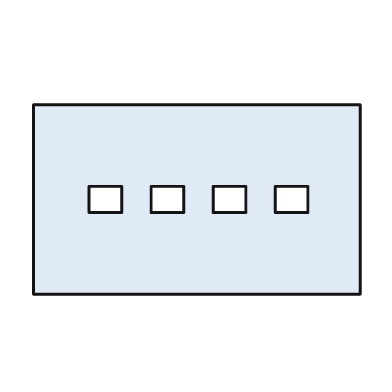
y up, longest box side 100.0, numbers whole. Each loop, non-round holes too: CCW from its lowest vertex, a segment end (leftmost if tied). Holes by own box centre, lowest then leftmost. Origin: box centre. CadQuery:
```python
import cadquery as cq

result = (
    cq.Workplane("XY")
    .moveTo(-50.0, -29.0)
    .lineTo(50.0, -29.0)
    .lineTo(50.0, 29.0)
    .lineTo(-50.0, 29.0)
    .close()
    .moveTo(-33.0, -4.0)
    .lineTo(-23.0, -4.0)
    .lineTo(-23.0, 4.0)
    .lineTo(-33.0, 4.0)
    .close()
    .moveTo(-14.0, -4.0)
    .lineTo(-4.0, -4.0)
    .lineTo(-4.0, 4.0)
    .lineTo(-14.0, 4.0)
    .close()
    .moveTo(5.0, -4.0)
    .lineTo(15.0, -4.0)
    .lineTo(15.0, 4.0)
    .lineTo(5.0, 4.0)
    .close()
    .moveTo(24.0, -4.0)
    .lineTo(34.0, -4.0)
    .lineTo(34.0, 4.0)
    .lineTo(24.0, 4.0)
    .close()
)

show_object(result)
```